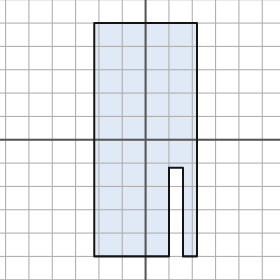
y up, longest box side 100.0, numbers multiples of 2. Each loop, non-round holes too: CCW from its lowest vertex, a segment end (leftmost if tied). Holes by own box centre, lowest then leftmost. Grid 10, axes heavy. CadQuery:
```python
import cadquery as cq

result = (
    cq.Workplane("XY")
    .moveTo(-22.0, -50.0)
    .lineTo(10.0, -50.0)
    .lineTo(10.0, -12.0)
    .lineTo(16.0, -12.0)
    .lineTo(16.0, -50.0)
    .lineTo(22.0, -50.0)
    .lineTo(22.0, 50.0)
    .lineTo(-22.0, 50.0)
    .close()
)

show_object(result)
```